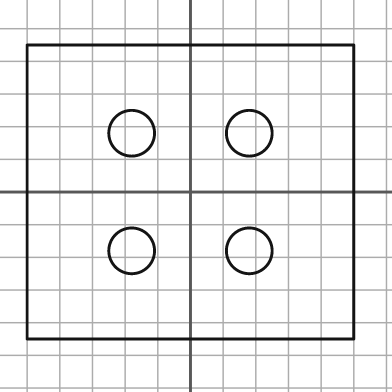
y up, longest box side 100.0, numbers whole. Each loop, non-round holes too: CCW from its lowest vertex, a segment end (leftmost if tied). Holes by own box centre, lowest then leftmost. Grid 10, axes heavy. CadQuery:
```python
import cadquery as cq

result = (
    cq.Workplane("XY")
    .moveTo(-50.0, -45.0)
    .lineTo(50.0, -45.0)
    .lineTo(50.0, 45.0)
    .lineTo(-50.0, 45.0)
    .close()
    .moveTo(-18.0, -18.0)
    .circle(7.0)
    .moveTo(18.0, -18.0)
    .circle(7.0)
    .moveTo(-18.0, 18.0)
    .circle(7.0)
    .moveTo(18.0, 18.0)
    .circle(7.0)
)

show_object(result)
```